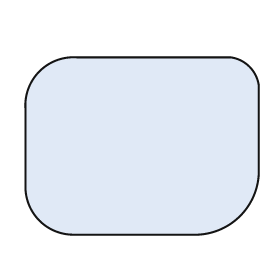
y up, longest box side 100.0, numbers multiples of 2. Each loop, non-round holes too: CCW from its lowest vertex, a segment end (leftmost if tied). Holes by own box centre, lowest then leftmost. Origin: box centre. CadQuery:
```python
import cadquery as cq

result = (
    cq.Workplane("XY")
    .moveTo(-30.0, -38.0)
    .lineTo(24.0, -38.0)
    .threePointArc((42.0, -30.0), (50.0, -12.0))
    .lineTo(50.0, 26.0)
    .threePointArc((46.0, 34.0), (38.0, 38.0))
    .lineTo(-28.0, 38.0)
    .threePointArc((-44.0, 32.0), (-50.0, 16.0))
    .lineTo(-50.0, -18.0)
    .threePointArc((-44.0, -32.0), (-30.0, -38.0))
    .close()
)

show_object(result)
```